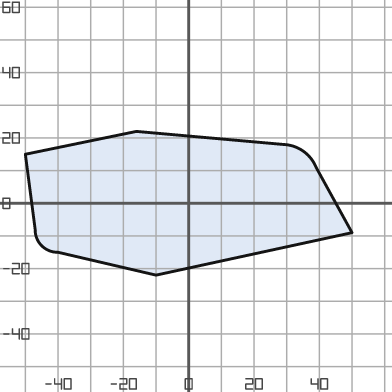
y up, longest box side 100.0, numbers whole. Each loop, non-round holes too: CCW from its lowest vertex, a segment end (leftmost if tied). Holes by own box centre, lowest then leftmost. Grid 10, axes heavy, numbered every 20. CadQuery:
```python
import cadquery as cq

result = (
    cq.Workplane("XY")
    .moveTo(-10.0, -22.0)
    .lineTo(50.0, -9.0)
    .lineTo(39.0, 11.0)
    .threePointArc((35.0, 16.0), (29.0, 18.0))
    .lineTo(-16.0, 22.0)
    .lineTo(-50.0, 15.0)
    .lineTo(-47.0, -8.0)
    .threePointArc((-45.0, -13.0), (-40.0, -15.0))
    .close()
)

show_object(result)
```